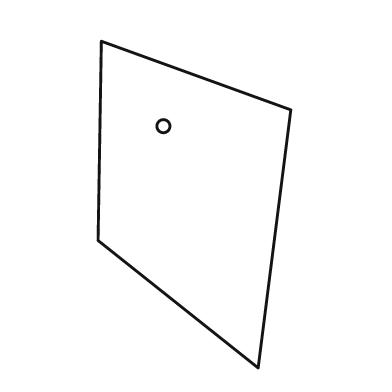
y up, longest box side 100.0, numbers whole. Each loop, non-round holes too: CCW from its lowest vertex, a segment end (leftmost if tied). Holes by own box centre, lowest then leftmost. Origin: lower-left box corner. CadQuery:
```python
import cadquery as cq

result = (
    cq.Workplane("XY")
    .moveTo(49.0, 0.0)
    .lineTo(59.0, 79.0)
    .lineTo(1.0, 100.0)
    .lineTo(0.0, 39.0)
    .close()
    .moveTo(20.0, 74.0)
    .circle(2.0)
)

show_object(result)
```